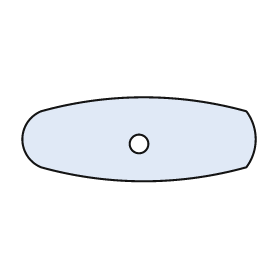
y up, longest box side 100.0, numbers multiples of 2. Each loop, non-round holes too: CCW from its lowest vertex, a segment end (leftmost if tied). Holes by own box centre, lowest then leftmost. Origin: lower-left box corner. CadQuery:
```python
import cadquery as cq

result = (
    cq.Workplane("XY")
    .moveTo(8.0, 6.0)
    .threePointArc((52.0, 0.0), (96.0, 6.0))
    .threePointArc((100.0, 18.0), (96.0, 30.0))
    .threePointArc((52.0, 36.0), (8.0, 30.0))
    .threePointArc((0.0, 18.0), (8.0, 6.0))
    .close()
    .moveTo(50.0, 16.0)
    .circle(4.0)
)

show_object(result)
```